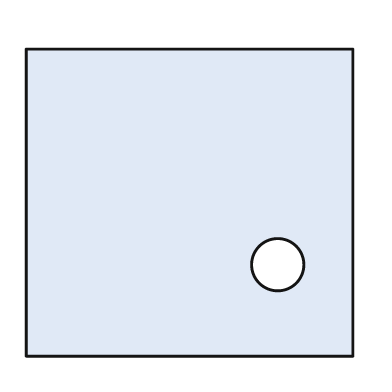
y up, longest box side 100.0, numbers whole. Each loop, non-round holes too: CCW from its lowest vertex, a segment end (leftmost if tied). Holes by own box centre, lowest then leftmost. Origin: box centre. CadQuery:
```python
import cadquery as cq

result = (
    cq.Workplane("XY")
    .moveTo(-50.0, -47.0)
    .lineTo(50.0, -47.0)
    .lineTo(50.0, 47.0)
    .lineTo(-50.0, 47.0)
    .close()
    .moveTo(27.0, -19.0)
    .circle(8.0)
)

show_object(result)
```